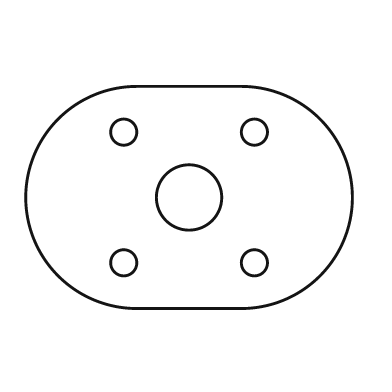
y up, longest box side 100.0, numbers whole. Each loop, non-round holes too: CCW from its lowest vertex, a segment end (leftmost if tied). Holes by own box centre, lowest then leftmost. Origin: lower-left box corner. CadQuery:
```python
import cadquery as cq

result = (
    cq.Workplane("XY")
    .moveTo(34.0, 0.0)
    .lineTo(66.0, 0.0)
    .threePointArc((100.0, 34.0), (66.0, 68.0))
    .lineTo(34.0, 68.0)
    .threePointArc((0.0, 34.0), (34.0, 0.0))
    .close()
    .moveTo(30.0, 14.0)
    .circle(4.0)
    .moveTo(70.0, 14.0)
    .circle(4.0)
    .moveTo(50.0, 34.0)
    .circle(10.0)
    .moveTo(30.0, 54.0)
    .circle(4.0)
    .moveTo(70.0, 54.0)
    .circle(4.0)
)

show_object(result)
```